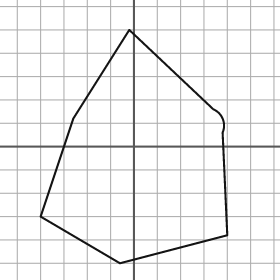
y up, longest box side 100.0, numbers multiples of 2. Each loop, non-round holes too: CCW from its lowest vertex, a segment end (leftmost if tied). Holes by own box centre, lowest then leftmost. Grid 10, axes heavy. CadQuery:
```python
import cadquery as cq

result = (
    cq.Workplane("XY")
    .moveTo(-6.0, -50.0)
    .lineTo(40.0, -38.0)
    .lineTo(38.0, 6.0)
    .threePointArc((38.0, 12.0), (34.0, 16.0))
    .lineTo(-2.0, 50.0)
    .lineTo(-26.0, 12.0)
    .lineTo(-40.0, -30.0)
    .close()
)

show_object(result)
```